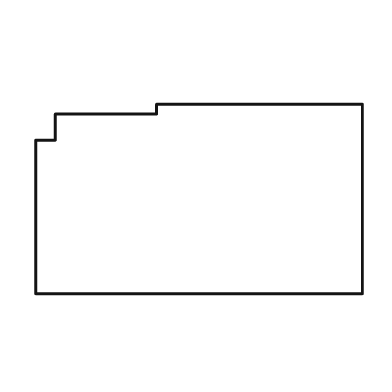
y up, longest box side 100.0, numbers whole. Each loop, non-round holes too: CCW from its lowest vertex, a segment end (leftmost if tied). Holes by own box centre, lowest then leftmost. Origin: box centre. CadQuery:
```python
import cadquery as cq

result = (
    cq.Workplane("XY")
    .moveTo(-50.0, -29.0)
    .lineTo(50.0, -29.0)
    .lineTo(50.0, 29.0)
    .lineTo(-13.0, 29.0)
    .lineTo(-13.0, 26.0)
    .lineTo(-44.0, 26.0)
    .lineTo(-44.0, 18.0)
    .lineTo(-50.0, 18.0)
    .close()
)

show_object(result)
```